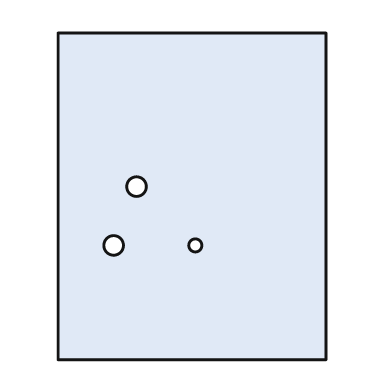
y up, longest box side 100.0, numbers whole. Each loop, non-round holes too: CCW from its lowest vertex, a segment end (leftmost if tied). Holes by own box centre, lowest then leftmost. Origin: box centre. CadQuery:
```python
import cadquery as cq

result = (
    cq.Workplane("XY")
    .moveTo(-41.0, -50.0)
    .lineTo(41.0, -50.0)
    .lineTo(41.0, 50.0)
    .lineTo(-41.0, 50.0)
    .close()
    .moveTo(-24.0, -15.0)
    .circle(3.0)
    .moveTo(1.0, -15.0)
    .circle(2.0)
    .moveTo(-17.0, 3.0)
    .circle(3.0)
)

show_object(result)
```